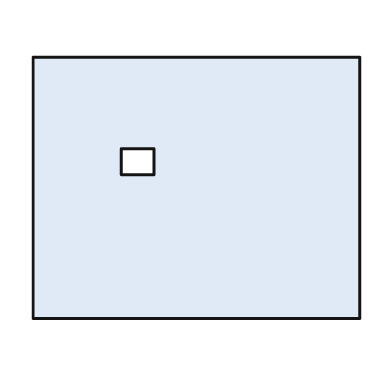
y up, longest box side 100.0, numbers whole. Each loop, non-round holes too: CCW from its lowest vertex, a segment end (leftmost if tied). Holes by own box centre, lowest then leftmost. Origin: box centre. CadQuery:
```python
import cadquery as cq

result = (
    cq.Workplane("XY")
    .moveTo(-50.0, -40.0)
    .lineTo(50.0, -40.0)
    .lineTo(50.0, 40.0)
    .lineTo(-50.0, 40.0)
    .close()
    .moveTo(-23.0, 4.0)
    .lineTo(-13.0, 4.0)
    .lineTo(-13.0, 12.0)
    .lineTo(-23.0, 12.0)
    .close()
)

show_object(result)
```